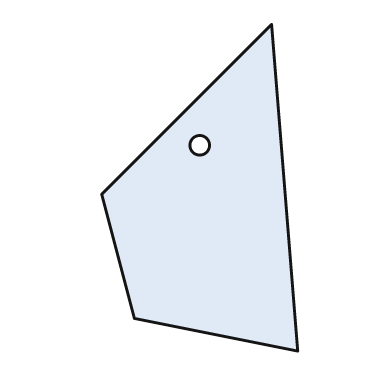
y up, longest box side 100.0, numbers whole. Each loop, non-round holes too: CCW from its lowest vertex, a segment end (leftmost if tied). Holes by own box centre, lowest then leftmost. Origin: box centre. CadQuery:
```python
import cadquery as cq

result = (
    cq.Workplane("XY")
    .moveTo(30.0, -50.0)
    .lineTo(22.0, 50.0)
    .lineTo(-30.0, -2.0)
    .lineTo(-20.0, -40.0)
    .close()
    .moveTo(0.0, 13.0)
    .circle(3.0)
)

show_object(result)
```